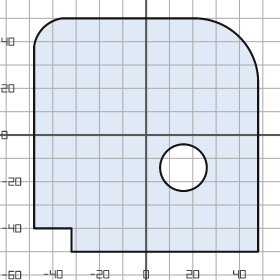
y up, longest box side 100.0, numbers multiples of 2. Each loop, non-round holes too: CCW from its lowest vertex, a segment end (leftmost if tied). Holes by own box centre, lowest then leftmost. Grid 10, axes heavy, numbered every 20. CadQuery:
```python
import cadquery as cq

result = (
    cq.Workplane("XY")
    .moveTo(-32.0, -50.0)
    .lineTo(48.0, -50.0)
    .lineTo(48.0, 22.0)
    .threePointArc((40.0, 42.0), (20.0, 50.0))
    .lineTo(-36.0, 50.0)
    .threePointArc((-44.0, 46.0), (-48.0, 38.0))
    .lineTo(-48.0, -40.0)
    .lineTo(-32.0, -40.0)
    .close()
    .moveTo(16.0, -14.0)
    .circle(10.0)
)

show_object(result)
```